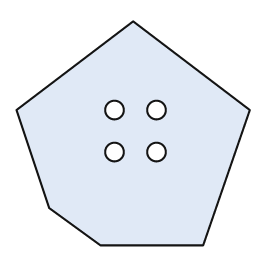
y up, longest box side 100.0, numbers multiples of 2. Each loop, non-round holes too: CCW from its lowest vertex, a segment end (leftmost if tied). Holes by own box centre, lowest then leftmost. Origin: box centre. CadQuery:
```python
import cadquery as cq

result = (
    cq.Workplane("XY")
    .moveTo(-14.0, -48.0)
    .lineTo(30.0, -48.0)
    .lineTo(50.0, 10.0)
    .lineTo(0.0, 48.0)
    .lineTo(-50.0, 10.0)
    .lineTo(-36.0, -32.0)
    .close()
    .moveTo(-8.0, -8.0)
    .circle(4.0)
    .moveTo(10.0, -8.0)
    .circle(4.0)
    .moveTo(-8.0, 10.0)
    .circle(4.0)
    .moveTo(10.0, 10.0)
    .circle(4.0)
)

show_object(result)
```